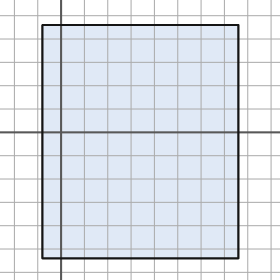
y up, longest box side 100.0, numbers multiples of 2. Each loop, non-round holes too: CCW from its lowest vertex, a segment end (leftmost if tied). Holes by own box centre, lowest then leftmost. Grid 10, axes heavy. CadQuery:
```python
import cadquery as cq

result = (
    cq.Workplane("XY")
    .moveTo(-8.0, -54.0)
    .lineTo(76.0, -54.0)
    .lineTo(76.0, 46.0)
    .lineTo(-8.0, 46.0)
    .close()
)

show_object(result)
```